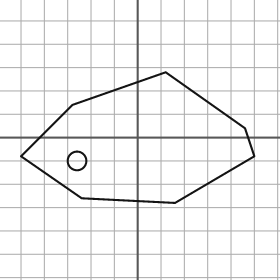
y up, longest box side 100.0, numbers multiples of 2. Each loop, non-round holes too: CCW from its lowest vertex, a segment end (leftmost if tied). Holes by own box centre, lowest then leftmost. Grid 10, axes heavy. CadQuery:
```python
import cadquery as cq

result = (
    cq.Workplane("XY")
    .moveTo(16.0, -28.0)
    .lineTo(50.0, -8.0)
    .lineTo(46.0, 4.0)
    .lineTo(12.0, 28.0)
    .lineTo(-28.0, 14.0)
    .lineTo(-50.0, -8.0)
    .lineTo(-24.0, -26.0)
    .close()
    .moveTo(-26.0, -10.0)
    .circle(4.0)
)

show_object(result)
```